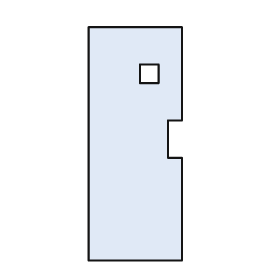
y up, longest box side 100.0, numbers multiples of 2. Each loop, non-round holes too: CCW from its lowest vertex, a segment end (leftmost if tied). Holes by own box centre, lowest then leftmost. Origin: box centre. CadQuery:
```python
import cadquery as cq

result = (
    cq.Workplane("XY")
    .moveTo(-20.0, -50.0)
    .lineTo(20.0, -50.0)
    .lineTo(20.0, -6.0)
    .lineTo(14.0, -6.0)
    .lineTo(14.0, 10.0)
    .lineTo(20.0, 10.0)
    .lineTo(20.0, 50.0)
    .lineTo(-20.0, 50.0)
    .close()
    .moveTo(2.0, 26.0)
    .lineTo(10.0, 26.0)
    .lineTo(10.0, 34.0)
    .lineTo(2.0, 34.0)
    .close()
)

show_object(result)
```